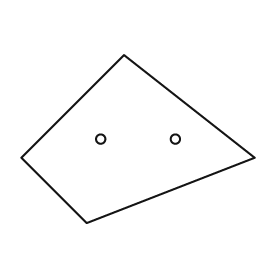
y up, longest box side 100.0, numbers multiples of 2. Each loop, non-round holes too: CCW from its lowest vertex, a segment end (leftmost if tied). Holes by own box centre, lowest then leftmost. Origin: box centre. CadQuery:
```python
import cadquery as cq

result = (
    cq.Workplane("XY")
    .moveTo(-22.0, -36.0)
    .lineTo(50.0, -8.0)
    .lineTo(-6.0, 36.0)
    .lineTo(-50.0, -8.0)
    .close()
    .moveTo(-16.0, 0.0)
    .circle(2.0)
    .moveTo(16.0, 0.0)
    .circle(2.0)
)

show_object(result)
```